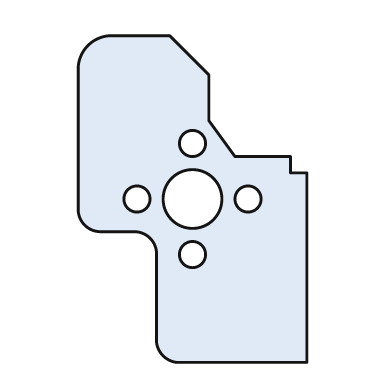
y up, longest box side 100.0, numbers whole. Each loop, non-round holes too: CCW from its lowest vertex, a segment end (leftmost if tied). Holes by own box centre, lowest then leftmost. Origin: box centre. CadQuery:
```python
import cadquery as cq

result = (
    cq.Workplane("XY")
    .moveTo(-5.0, -50.0)
    .lineTo(35.0, -50.0)
    .lineTo(35.0, 8.0)
    .lineTo(30.0, 8.0)
    .lineTo(30.0, 13.0)
    .lineTo(13.0, 13.0)
    .lineTo(5.0, 24.0)
    .lineTo(5.0, 38.0)
    .lineTo(-7.0, 50.0)
    .lineTo(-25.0, 50.0)
    .threePointArc((-32.0, 47.0), (-35.0, 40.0))
    .lineTo(-35.0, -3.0)
    .threePointArc((-33.0, -8.0), (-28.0, -10.0))
    .lineTo(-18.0, -10.0)
    .threePointArc((-13.0, -12.0), (-11.0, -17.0))
    .lineTo(-11.0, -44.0)
    .threePointArc((-9.0, -48.0), (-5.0, -50.0))
    .close()
    .moveTo(0.0, -17.0)
    .circle(4.0)
    .moveTo(-17.0, 0.0)
    .circle(4.0)
    .moveTo(0.0, 0.0)
    .circle(9.0)
    .moveTo(17.0, 0.0)
    .circle(4.0)
    .moveTo(0.0, 17.0)
    .circle(4.0)
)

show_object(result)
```